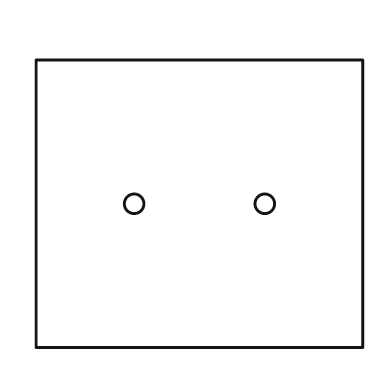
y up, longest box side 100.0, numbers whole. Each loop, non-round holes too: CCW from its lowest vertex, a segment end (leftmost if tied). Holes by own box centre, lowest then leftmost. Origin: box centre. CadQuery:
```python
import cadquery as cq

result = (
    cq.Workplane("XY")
    .moveTo(-50.0, -44.0)
    .lineTo(50.0, -44.0)
    .lineTo(50.0, 44.0)
    .lineTo(-50.0, 44.0)
    .close()
    .moveTo(-20.0, 0.0)
    .circle(3.0)
    .moveTo(20.0, 0.0)
    .circle(3.0)
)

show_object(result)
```